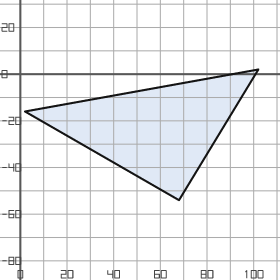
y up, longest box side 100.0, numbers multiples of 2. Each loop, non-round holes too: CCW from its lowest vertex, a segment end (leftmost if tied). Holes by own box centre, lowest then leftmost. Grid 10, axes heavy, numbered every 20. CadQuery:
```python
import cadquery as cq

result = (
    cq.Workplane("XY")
    .moveTo(68.0, -54.0)
    .lineTo(102.0, 2.0)
    .lineTo(2.0, -16.0)
    .close()
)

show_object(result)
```